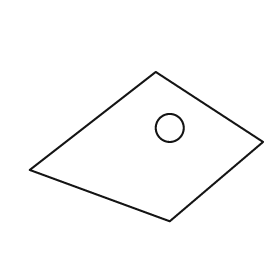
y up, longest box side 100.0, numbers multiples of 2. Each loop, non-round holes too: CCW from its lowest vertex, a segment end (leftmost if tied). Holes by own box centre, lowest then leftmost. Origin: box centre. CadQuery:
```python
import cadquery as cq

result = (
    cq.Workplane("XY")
    .moveTo(10.0, -32.0)
    .lineTo(50.0, 2.0)
    .lineTo(4.0, 32.0)
    .lineTo(-50.0, -10.0)
    .close()
    .moveTo(10.0, 8.0)
    .circle(6.0)
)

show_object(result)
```